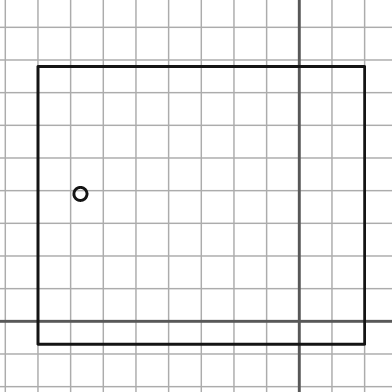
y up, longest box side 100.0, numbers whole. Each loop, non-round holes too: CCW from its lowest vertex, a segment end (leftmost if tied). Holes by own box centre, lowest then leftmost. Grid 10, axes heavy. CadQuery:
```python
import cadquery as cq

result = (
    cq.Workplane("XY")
    .moveTo(-80.0, -7.0)
    .lineTo(20.0, -7.0)
    .lineTo(20.0, 78.0)
    .lineTo(-80.0, 78.0)
    .close()
    .moveTo(-67.0, 39.0)
    .circle(2.0)
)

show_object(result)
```